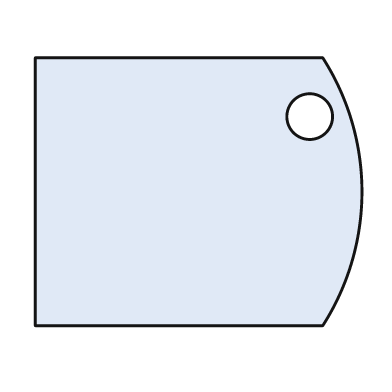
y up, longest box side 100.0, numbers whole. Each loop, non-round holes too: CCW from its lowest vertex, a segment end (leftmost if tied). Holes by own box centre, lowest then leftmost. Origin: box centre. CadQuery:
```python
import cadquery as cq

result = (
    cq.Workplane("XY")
    .moveTo(-50.0, -41.0)
    .lineTo(38.0, -41.0)
    .threePointArc((50.0, 0.0), (38.0, 41.0))
    .lineTo(-50.0, 41.0)
    .close()
    .moveTo(34.0, 23.0)
    .circle(7.0)
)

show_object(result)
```